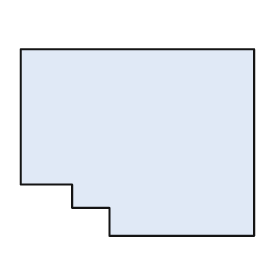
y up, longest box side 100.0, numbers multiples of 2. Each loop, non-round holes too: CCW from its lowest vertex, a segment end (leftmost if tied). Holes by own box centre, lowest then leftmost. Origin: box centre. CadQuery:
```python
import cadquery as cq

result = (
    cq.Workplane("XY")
    .moveTo(-12.0, -40.0)
    .lineTo(50.0, -40.0)
    .lineTo(50.0, 40.0)
    .lineTo(-50.0, 40.0)
    .lineTo(-50.0, -18.0)
    .lineTo(-28.0, -18.0)
    .lineTo(-28.0, -28.0)
    .lineTo(-12.0, -28.0)
    .close()
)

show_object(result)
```